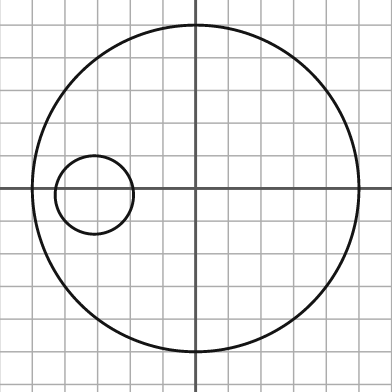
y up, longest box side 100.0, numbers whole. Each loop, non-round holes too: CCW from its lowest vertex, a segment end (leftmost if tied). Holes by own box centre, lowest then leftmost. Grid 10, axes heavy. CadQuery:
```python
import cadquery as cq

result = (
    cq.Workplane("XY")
    .moveTo(0.0, 0.0)
    .circle(50.0)
    .moveTo(-31.0, -2.0)
    .circle(12.0)
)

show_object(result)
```